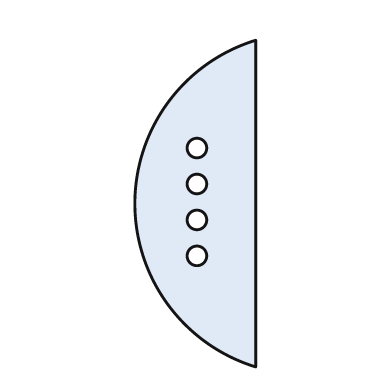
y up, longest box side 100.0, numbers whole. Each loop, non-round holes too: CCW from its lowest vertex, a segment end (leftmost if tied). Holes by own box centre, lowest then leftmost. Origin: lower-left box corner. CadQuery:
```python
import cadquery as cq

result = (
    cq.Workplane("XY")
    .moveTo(37.0, 0.0)
    .lineTo(37.0, 100.0)
    .threePointArc((0.0, 50.0), (37.0, 0.0))
    .close()
    .moveTo(19.0, 34.0)
    .circle(3.0)
    .moveTo(19.0, 45.0)
    .circle(3.0)
    .moveTo(19.0, 56.0)
    .circle(3.0)
    .moveTo(19.0, 67.0)
    .circle(3.0)
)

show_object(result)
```